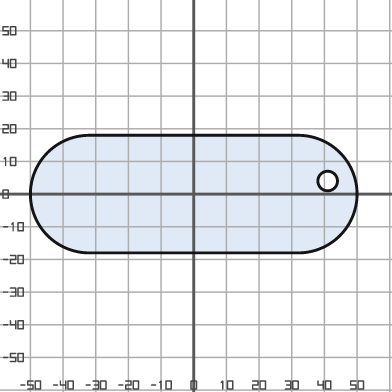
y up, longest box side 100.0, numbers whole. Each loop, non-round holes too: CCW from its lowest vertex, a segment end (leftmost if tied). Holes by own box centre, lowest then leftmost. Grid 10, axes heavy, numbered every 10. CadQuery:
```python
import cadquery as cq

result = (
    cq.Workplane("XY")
    .moveTo(-32.0, -18.0)
    .lineTo(32.0, -18.0)
    .threePointArc((50.0, 0.0), (32.0, 18.0))
    .lineTo(-32.0, 18.0)
    .threePointArc((-50.0, 0.0), (-32.0, -18.0))
    .close()
    .moveTo(41.0, 4.0)
    .circle(3.0)
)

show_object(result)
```